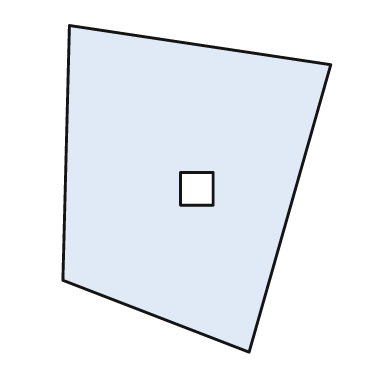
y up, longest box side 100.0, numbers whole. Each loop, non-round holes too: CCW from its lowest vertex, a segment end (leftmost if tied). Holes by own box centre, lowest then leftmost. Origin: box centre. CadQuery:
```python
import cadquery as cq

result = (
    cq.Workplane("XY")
    .moveTo(16.0, -50.0)
    .lineTo(41.0, 38.0)
    .lineTo(-39.0, 50.0)
    .lineTo(-41.0, -28.0)
    .close()
    .moveTo(-5.0, -5.0)
    .lineTo(5.0, -5.0)
    .lineTo(5.0, 5.0)
    .lineTo(-5.0, 5.0)
    .close()
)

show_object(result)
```